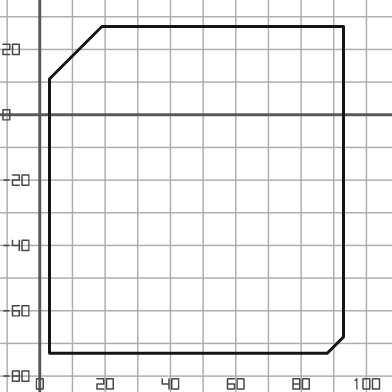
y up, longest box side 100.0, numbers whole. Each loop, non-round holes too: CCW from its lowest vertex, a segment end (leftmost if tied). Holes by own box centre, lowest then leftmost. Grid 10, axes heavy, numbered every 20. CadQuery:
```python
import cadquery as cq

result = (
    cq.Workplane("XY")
    .moveTo(3.0, -73.0)
    .lineTo(88.0, -73.0)
    .lineTo(93.0, -68.0)
    .lineTo(93.0, 27.0)
    .lineTo(19.0, 27.0)
    .lineTo(3.0, 11.0)
    .close()
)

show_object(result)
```